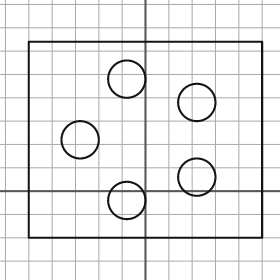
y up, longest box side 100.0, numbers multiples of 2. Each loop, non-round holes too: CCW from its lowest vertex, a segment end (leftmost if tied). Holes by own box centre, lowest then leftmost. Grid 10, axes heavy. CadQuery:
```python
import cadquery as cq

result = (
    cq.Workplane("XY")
    .moveTo(-50.0, -20.0)
    .lineTo(50.0, -20.0)
    .lineTo(50.0, 64.0)
    .lineTo(-50.0, 64.0)
    .close()
    .moveTo(-8.0, -4.0)
    .circle(8.0)
    .moveTo(22.0, 6.0)
    .circle(8.0)
    .moveTo(-28.0, 22.0)
    .circle(8.0)
    .moveTo(22.0, 38.0)
    .circle(8.0)
    .moveTo(-8.0, 48.0)
    .circle(8.0)
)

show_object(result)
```